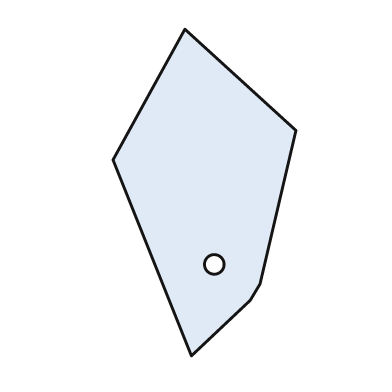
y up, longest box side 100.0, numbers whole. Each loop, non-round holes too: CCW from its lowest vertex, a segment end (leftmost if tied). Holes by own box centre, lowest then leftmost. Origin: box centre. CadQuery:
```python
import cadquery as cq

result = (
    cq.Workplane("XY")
    .moveTo(-4.0, -50.0)
    .lineTo(14.0, -33.0)
    .lineTo(17.0, -28.0)
    .lineTo(28.0, 19.0)
    .lineTo(-6.0, 50.0)
    .lineTo(-28.0, 10.0)
    .close()
    .moveTo(3.0, -22.0)
    .circle(3.0)
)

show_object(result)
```